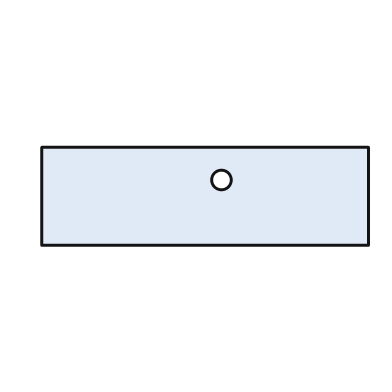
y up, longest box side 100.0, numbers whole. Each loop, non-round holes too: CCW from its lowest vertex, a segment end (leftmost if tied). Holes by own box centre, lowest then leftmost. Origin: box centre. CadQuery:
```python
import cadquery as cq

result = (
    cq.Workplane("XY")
    .moveTo(-50.0, -15.0)
    .lineTo(50.0, -15.0)
    .lineTo(50.0, 15.0)
    .lineTo(-50.0, 15.0)
    .close()
    .moveTo(5.0, 5.0)
    .circle(3.0)
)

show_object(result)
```